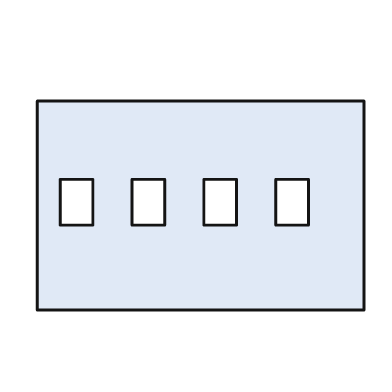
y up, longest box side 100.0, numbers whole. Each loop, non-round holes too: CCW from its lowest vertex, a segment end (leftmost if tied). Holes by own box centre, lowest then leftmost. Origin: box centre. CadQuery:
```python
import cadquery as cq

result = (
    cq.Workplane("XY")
    .moveTo(-50.0, -32.0)
    .lineTo(50.0, -32.0)
    .lineTo(50.0, 32.0)
    .lineTo(-50.0, 32.0)
    .close()
    .moveTo(-43.0, -6.0)
    .lineTo(-33.0, -6.0)
    .lineTo(-33.0, 8.0)
    .lineTo(-43.0, 8.0)
    .close()
    .moveTo(-21.0, -6.0)
    .lineTo(-11.0, -6.0)
    .lineTo(-11.0, 8.0)
    .lineTo(-21.0, 8.0)
    .close()
    .moveTo(1.0, -6.0)
    .lineTo(11.0, -6.0)
    .lineTo(11.0, 8.0)
    .lineTo(1.0, 8.0)
    .close()
    .moveTo(23.0, -6.0)
    .lineTo(33.0, -6.0)
    .lineTo(33.0, 8.0)
    .lineTo(23.0, 8.0)
    .close()
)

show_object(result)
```